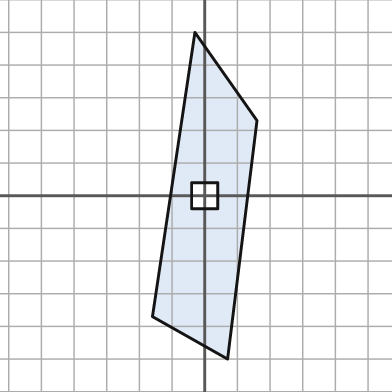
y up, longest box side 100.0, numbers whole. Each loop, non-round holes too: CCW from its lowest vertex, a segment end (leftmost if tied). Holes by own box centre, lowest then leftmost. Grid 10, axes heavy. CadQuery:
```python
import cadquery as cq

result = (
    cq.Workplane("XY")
    .moveTo(7.0, -50.0)
    .lineTo(16.0, 23.0)
    .lineTo(-3.0, 50.0)
    .lineTo(-16.0, -37.0)
    .close()
    .moveTo(-4.0, -4.0)
    .lineTo(4.0, -4.0)
    .lineTo(4.0, 4.0)
    .lineTo(-4.0, 4.0)
    .close()
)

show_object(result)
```